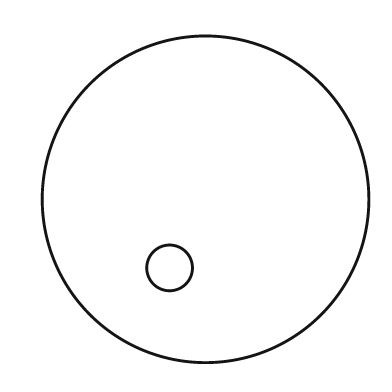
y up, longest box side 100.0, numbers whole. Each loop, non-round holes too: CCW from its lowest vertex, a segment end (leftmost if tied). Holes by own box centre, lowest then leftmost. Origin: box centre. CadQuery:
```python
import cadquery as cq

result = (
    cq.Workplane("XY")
    .moveTo(0.0, 0.0)
    .circle(50.0)
    .moveTo(-11.0, -21.0)
    .circle(7.0)
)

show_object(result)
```